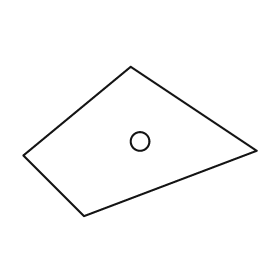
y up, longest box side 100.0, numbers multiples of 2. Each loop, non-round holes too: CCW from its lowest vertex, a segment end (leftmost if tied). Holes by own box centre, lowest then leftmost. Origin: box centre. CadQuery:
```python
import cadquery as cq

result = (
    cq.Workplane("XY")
    .moveTo(-24.0, -32.0)
    .lineTo(50.0, -4.0)
    .lineTo(-4.0, 32.0)
    .lineTo(-50.0, -6.0)
    .close()
    .moveTo(0.0, 0.0)
    .circle(4.0)
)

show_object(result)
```